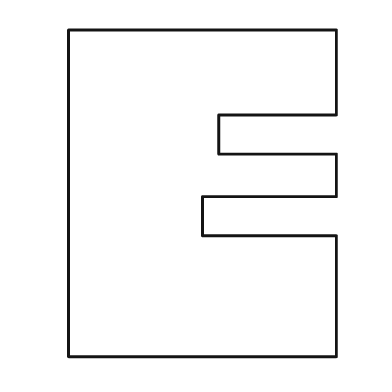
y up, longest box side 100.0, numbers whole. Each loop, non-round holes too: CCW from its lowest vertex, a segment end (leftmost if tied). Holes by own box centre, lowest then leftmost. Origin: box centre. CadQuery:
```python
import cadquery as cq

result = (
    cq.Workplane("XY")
    .moveTo(-41.0, -50.0)
    .lineTo(41.0, -50.0)
    .lineTo(41.0, -13.0)
    .lineTo(0.0, -13.0)
    .lineTo(0.0, -1.0)
    .lineTo(41.0, -1.0)
    .lineTo(41.0, 12.0)
    .lineTo(5.0, 12.0)
    .lineTo(5.0, 24.0)
    .lineTo(41.0, 24.0)
    .lineTo(41.0, 50.0)
    .lineTo(-41.0, 50.0)
    .close()
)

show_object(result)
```